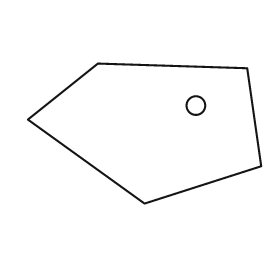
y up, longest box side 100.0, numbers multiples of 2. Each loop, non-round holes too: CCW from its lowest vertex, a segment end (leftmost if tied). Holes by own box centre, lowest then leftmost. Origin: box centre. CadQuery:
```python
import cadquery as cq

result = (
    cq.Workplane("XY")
    .moveTo(0.0, -30.0)
    .lineTo(50.0, -14.0)
    .lineTo(44.0, 28.0)
    .lineTo(-20.0, 30.0)
    .lineTo(-50.0, 6.0)
    .close()
    .moveTo(22.0, 12.0)
    .circle(4.0)
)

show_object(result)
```